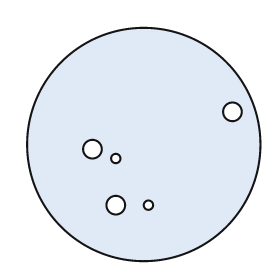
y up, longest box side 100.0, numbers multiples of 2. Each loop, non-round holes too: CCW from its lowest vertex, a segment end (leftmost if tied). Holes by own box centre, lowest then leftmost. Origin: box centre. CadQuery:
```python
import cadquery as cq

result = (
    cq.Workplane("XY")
    .moveTo(0.0, 0.0)
    .circle(50.0)
    .moveTo(-12.0, -26.0)
    .circle(4.0)
    .moveTo(2.0, -26.0)
    .circle(2.0)
    .moveTo(-12.0, -6.0)
    .circle(2.0)
    .moveTo(-22.0, -2.0)
    .circle(4.0)
    .moveTo(38.0, 14.0)
    .circle(4.0)
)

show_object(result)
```